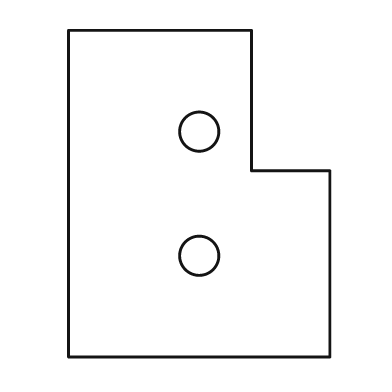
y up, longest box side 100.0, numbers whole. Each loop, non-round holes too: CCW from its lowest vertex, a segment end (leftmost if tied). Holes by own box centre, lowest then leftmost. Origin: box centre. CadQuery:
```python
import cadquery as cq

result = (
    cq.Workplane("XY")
    .moveTo(-40.0, -50.0)
    .lineTo(40.0, -50.0)
    .lineTo(40.0, 7.0)
    .lineTo(16.0, 7.0)
    .lineTo(16.0, 50.0)
    .lineTo(-40.0, 50.0)
    .close()
    .moveTo(0.0, -19.0)
    .circle(6.0)
    .moveTo(0.0, 19.0)
    .circle(6.0)
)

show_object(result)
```